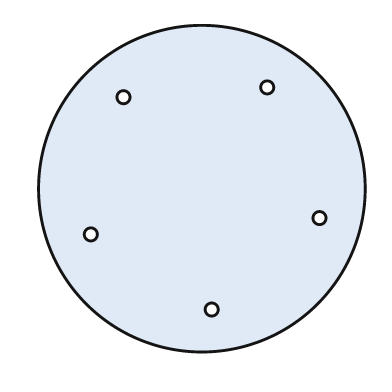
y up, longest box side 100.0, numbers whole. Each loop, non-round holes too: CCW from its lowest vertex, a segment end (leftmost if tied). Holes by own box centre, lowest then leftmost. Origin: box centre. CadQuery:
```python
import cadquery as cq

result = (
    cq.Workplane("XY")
    .moveTo(0.0, 0.0)
    .circle(50.0)
    .moveTo(3.0, -37.0)
    .circle(2.0)
    .moveTo(-34.0, -14.0)
    .circle(2.0)
    .moveTo(36.0, -9.0)
    .circle(2.0)
    .moveTo(-24.0, 28.0)
    .circle(2.0)
    .moveTo(20.0, 31.0)
    .circle(2.0)
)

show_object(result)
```